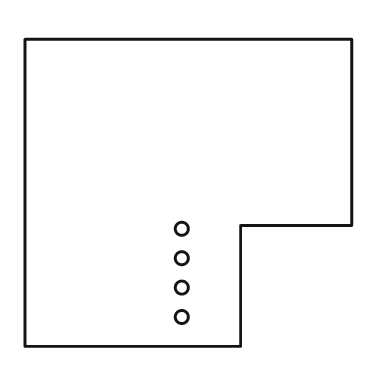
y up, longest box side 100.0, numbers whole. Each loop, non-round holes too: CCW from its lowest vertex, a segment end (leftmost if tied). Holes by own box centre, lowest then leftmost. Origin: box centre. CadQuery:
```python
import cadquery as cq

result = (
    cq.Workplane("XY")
    .moveTo(-50.0, -47.0)
    .lineTo(16.0, -47.0)
    .lineTo(16.0, -10.0)
    .lineTo(50.0, -10.0)
    .lineTo(50.0, 47.0)
    .lineTo(-50.0, 47.0)
    .close()
    .moveTo(-2.0, -38.0)
    .circle(2.0)
    .moveTo(-2.0, -29.0)
    .circle(2.0)
    .moveTo(-2.0, -20.0)
    .circle(2.0)
    .moveTo(-2.0, -11.0)
    .circle(2.0)
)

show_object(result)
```